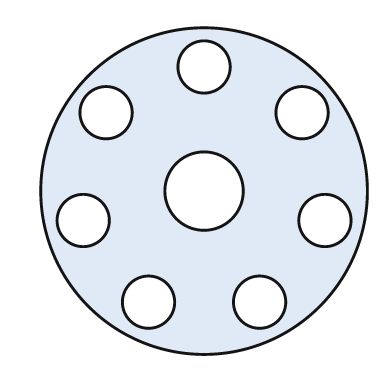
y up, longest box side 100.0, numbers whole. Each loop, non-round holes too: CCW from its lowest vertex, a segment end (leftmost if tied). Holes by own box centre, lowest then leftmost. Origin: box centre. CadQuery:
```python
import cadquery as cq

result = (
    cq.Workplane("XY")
    .moveTo(0.0, 0.0)
    .circle(50.0)
    .moveTo(-17.0, -34.0)
    .circle(8.0)
    .moveTo(17.0, -34.0)
    .circle(8.0)
    .moveTo(-37.0, -9.0)
    .circle(8.0)
    .moveTo(37.0, -9.0)
    .circle(8.0)
    .moveTo(0.0, 0.0)
    .circle(12.0)
    .moveTo(-30.0, 24.0)
    .circle(8.0)
    .moveTo(30.0, 24.0)
    .circle(8.0)
    .moveTo(0.0, 38.0)
    .circle(8.0)
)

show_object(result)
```